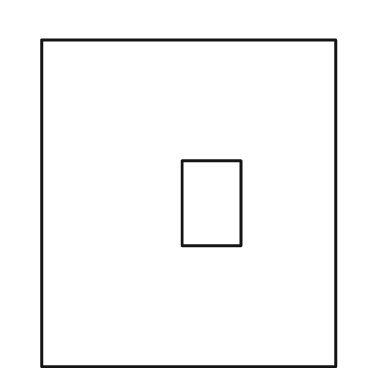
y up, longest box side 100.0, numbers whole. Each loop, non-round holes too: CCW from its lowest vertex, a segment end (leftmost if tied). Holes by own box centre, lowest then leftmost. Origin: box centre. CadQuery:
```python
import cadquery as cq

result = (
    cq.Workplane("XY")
    .moveTo(-45.0, -50.0)
    .lineTo(45.0, -50.0)
    .lineTo(45.0, 50.0)
    .lineTo(-45.0, 50.0)
    .close()
    .moveTo(-2.0, -13.0)
    .lineTo(16.0, -13.0)
    .lineTo(16.0, 13.0)
    .lineTo(-2.0, 13.0)
    .close()
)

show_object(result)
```